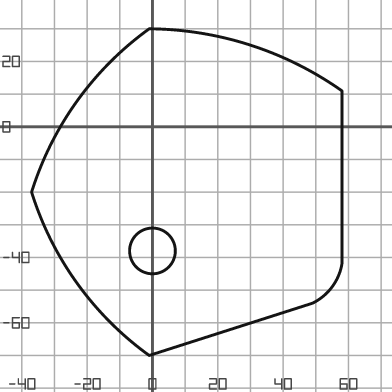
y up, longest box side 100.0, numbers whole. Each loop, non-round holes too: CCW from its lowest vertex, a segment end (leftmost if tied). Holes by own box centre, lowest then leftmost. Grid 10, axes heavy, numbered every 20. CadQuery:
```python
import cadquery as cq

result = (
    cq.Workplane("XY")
    .moveTo(-1.0, -70.0)
    .lineTo(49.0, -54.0)
    .threePointArc((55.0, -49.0), (58.0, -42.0))
    .lineTo(58.0, 11.0)
    .threePointArc((30.0, 25.0), (-1.0, 30.0))
    .threePointArc((-23.0, 8.0), (-37.0, -20.0))
    .threePointArc((-23.0, -48.0), (-1.0, -70.0))
    .close()
    .moveTo(0.0, -38.0)
    .circle(7.0)
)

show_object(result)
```